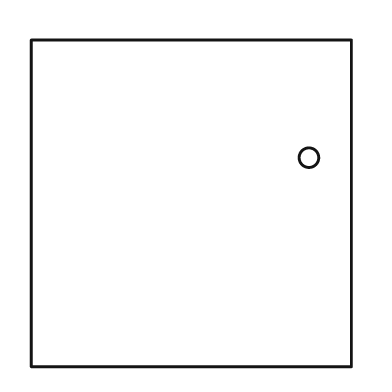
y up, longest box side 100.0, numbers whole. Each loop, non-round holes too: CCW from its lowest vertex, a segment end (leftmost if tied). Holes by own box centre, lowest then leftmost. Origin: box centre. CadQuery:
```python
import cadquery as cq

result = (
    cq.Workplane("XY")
    .moveTo(-49.0, -50.0)
    .lineTo(49.0, -50.0)
    .lineTo(49.0, 50.0)
    .lineTo(-49.0, 50.0)
    .close()
    .moveTo(36.0, 14.0)
    .circle(3.0)
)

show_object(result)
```